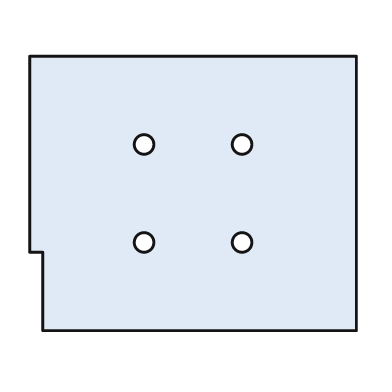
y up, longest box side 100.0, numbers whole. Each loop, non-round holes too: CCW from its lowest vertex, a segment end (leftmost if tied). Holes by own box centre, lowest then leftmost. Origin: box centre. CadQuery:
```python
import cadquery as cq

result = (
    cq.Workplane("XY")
    .moveTo(-46.0, -42.0)
    .lineTo(50.0, -42.0)
    .lineTo(50.0, 42.0)
    .lineTo(-50.0, 42.0)
    .lineTo(-50.0, -18.0)
    .lineTo(-46.0, -18.0)
    .close()
    .moveTo(-15.0, -15.0)
    .circle(3.0)
    .moveTo(15.0, -15.0)
    .circle(3.0)
    .moveTo(-15.0, 15.0)
    .circle(3.0)
    .moveTo(15.0, 15.0)
    .circle(3.0)
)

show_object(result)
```